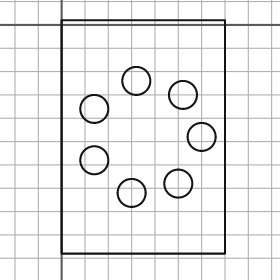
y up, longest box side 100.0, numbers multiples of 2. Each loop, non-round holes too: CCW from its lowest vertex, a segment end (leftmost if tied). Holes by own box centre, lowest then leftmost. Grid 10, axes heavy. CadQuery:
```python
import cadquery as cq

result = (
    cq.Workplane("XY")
    .moveTo(0.0, -98.0)
    .lineTo(70.0, -98.0)
    .lineTo(70.0, 2.0)
    .lineTo(0.0, 2.0)
    .close()
    .moveTo(30.0, -72.0)
    .circle(6.0)
    .moveTo(50.0, -68.0)
    .circle(6.0)
    .moveTo(14.0, -58.0)
    .circle(6.0)
    .moveTo(60.0, -48.0)
    .circle(6.0)
    .moveTo(14.0, -36.0)
    .circle(6.0)
    .moveTo(52.0, -30.0)
    .circle(6.0)
    .moveTo(32.0, -24.0)
    .circle(6.0)
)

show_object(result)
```